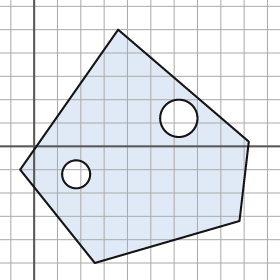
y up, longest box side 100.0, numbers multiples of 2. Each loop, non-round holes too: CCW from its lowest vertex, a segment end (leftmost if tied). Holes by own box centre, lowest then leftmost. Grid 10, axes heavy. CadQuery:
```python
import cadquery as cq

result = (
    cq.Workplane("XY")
    .moveTo(26.0, -50.0)
    .lineTo(88.0, -32.0)
    .lineTo(92.0, 2.0)
    .lineTo(36.0, 50.0)
    .lineTo(-6.0, -10.0)
    .close()
    .moveTo(18.0, -12.0)
    .circle(6.0)
    .moveTo(62.0, 12.0)
    .circle(8.0)
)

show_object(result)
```